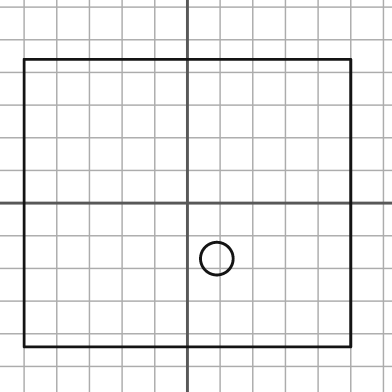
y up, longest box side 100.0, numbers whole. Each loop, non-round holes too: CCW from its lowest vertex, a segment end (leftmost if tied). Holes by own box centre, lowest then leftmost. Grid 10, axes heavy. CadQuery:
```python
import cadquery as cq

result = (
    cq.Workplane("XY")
    .moveTo(-50.0, -44.0)
    .lineTo(50.0, -44.0)
    .lineTo(50.0, 44.0)
    .lineTo(-50.0, 44.0)
    .close()
    .moveTo(9.0, -17.0)
    .circle(5.0)
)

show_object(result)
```